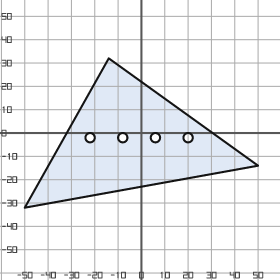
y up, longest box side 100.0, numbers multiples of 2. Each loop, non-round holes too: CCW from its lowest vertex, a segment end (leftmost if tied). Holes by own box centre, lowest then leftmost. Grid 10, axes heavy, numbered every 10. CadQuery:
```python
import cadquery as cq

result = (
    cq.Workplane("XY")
    .moveTo(-50.0, -32.0)
    .lineTo(50.0, -14.0)
    .lineTo(-14.0, 32.0)
    .close()
    .moveTo(-22.0, -2.0)
    .circle(2.0)
    .moveTo(-8.0, -2.0)
    .circle(2.0)
    .moveTo(6.0, -2.0)
    .circle(2.0)
    .moveTo(20.0, -2.0)
    .circle(2.0)
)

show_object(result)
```